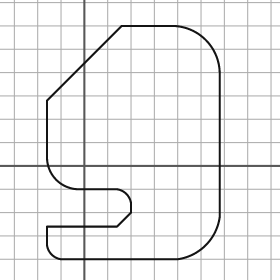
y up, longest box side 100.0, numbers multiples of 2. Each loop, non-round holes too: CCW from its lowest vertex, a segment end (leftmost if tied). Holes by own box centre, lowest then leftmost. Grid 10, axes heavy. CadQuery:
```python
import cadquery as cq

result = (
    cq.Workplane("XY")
    .moveTo(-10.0, -40.0)
    .lineTo(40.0, -40.0)
    .threePointArc((52.0, -34.0), (58.0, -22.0))
    .lineTo(58.0, 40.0)
    .threePointArc((52.0, 54.0), (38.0, 60.0))
    .lineTo(16.0, 60.0)
    .lineTo(-16.0, 28.0)
    .lineTo(-16.0, 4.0)
    .threePointArc((-12.0, -6.0), (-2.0, -10.0))
    .lineTo(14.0, -10.0)
    .threePointArc((18.0, -12.0), (20.0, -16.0))
    .lineTo(20.0, -20.0)
    .lineTo(14.0, -26.0)
    .lineTo(-16.0, -26.0)
    .lineTo(-16.0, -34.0)
    .threePointArc((-14.0, -38.0), (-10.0, -40.0))
    .close()
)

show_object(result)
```